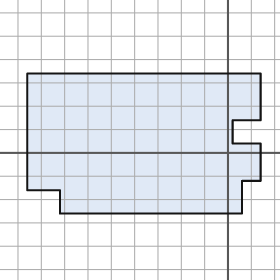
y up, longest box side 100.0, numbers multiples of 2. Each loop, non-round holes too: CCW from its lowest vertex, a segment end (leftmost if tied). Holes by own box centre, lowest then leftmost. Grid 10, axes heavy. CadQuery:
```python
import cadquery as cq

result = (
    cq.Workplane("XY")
    .moveTo(-72.0, -26.0)
    .lineTo(6.0, -26.0)
    .lineTo(6.0, -12.0)
    .lineTo(14.0, -12.0)
    .lineTo(14.0, 4.0)
    .lineTo(2.0, 4.0)
    .lineTo(2.0, 14.0)
    .lineTo(14.0, 14.0)
    .lineTo(14.0, 34.0)
    .lineTo(-86.0, 34.0)
    .lineTo(-86.0, -16.0)
    .lineTo(-72.0, -16.0)
    .close()
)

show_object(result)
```